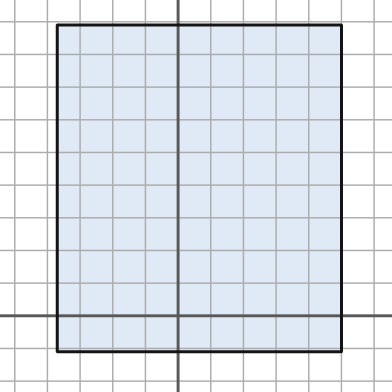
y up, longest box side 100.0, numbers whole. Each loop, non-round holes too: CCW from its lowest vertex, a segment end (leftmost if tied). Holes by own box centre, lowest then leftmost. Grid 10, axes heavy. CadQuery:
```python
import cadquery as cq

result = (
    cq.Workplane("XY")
    .moveTo(-37.0, -11.0)
    .lineTo(50.0, -11.0)
    .lineTo(50.0, 89.0)
    .lineTo(-37.0, 89.0)
    .close()
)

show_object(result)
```